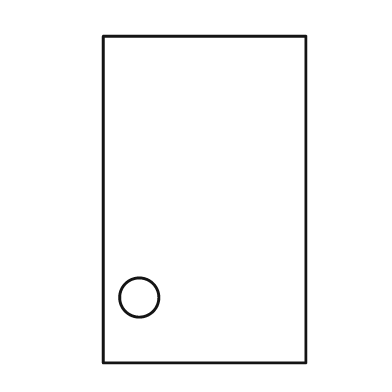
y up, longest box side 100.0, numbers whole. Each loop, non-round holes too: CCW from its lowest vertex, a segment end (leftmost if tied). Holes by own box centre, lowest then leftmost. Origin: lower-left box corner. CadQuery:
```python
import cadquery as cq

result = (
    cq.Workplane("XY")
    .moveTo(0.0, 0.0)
    .lineTo(62.0, 0.0)
    .lineTo(62.0, 100.0)
    .lineTo(0.0, 100.0)
    .close()
    .moveTo(11.0, 20.0)
    .circle(6.0)
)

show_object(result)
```